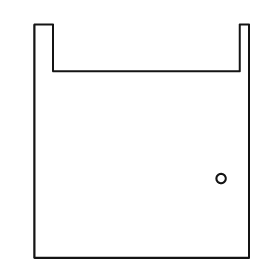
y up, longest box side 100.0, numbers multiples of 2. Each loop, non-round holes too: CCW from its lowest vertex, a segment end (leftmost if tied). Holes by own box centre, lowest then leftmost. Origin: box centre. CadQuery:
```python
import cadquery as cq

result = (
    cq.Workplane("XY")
    .moveTo(-46.0, -50.0)
    .lineTo(46.0, -50.0)
    .lineTo(46.0, 50.0)
    .lineTo(42.0, 50.0)
    .lineTo(42.0, 30.0)
    .lineTo(-38.0, 30.0)
    .lineTo(-38.0, 50.0)
    .lineTo(-46.0, 50.0)
    .close()
    .moveTo(34.0, -16.0)
    .circle(2.0)
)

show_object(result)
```